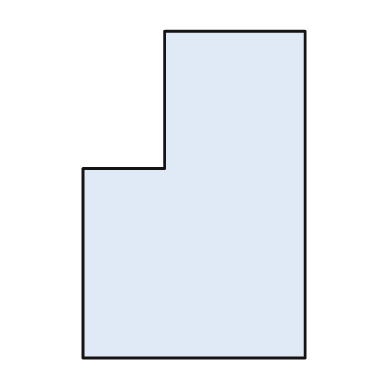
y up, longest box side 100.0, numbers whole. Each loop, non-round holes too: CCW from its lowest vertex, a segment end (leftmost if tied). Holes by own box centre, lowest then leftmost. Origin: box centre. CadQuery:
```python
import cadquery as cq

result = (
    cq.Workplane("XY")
    .moveTo(-34.0, -50.0)
    .lineTo(34.0, -50.0)
    .lineTo(34.0, 50.0)
    .lineTo(-9.0, 50.0)
    .lineTo(-9.0, 8.0)
    .lineTo(-34.0, 8.0)
    .close()
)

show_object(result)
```